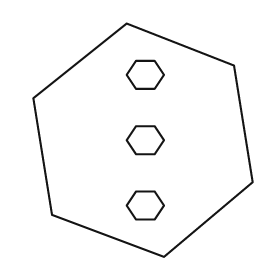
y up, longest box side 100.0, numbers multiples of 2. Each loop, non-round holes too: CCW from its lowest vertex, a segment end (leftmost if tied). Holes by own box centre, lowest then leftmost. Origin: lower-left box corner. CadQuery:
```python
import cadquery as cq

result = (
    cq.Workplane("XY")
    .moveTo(56.0, 0.0)
    .lineTo(94.0, 32.0)
    .lineTo(86.0, 82.0)
    .lineTo(40.0, 100.0)
    .lineTo(0.0, 68.0)
    .lineTo(8.0, 18.0)
    .close()
    .moveTo(44.0, 16.0)
    .lineTo(52.0, 16.0)
    .lineTo(56.0, 22.0)
    .lineTo(52.0, 28.0)
    .lineTo(44.0, 28.0)
    .lineTo(40.0, 22.0)
    .close()
    .moveTo(44.0, 44.0)
    .lineTo(52.0, 44.0)
    .lineTo(56.0, 50.0)
    .lineTo(52.0, 56.0)
    .lineTo(44.0, 56.0)
    .lineTo(40.0, 50.0)
    .close()
    .moveTo(44.0, 72.0)
    .lineTo(52.0, 72.0)
    .lineTo(56.0, 78.0)
    .lineTo(52.0, 84.0)
    .lineTo(44.0, 84.0)
    .lineTo(40.0, 78.0)
    .close()
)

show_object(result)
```